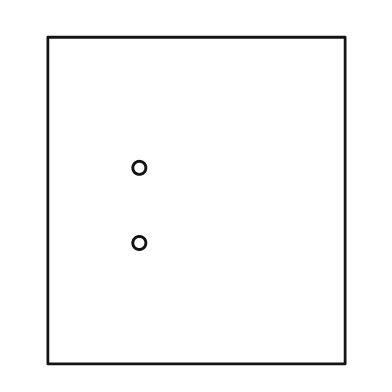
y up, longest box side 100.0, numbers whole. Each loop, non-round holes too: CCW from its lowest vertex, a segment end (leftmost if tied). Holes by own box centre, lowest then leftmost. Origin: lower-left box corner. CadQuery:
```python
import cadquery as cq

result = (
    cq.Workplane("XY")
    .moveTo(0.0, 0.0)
    .lineTo(91.0, 0.0)
    .lineTo(91.0, 100.0)
    .lineTo(0.0, 100.0)
    .close()
    .moveTo(28.0, 37.0)
    .circle(2.0)
    .moveTo(28.0, 60.0)
    .circle(2.0)
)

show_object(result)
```